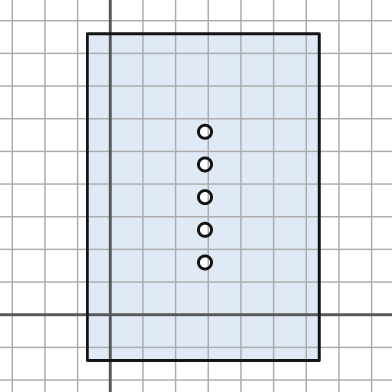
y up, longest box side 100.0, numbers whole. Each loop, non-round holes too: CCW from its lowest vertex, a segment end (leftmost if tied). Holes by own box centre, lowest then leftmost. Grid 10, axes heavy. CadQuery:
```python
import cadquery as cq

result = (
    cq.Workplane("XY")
    .moveTo(-7.0, -14.0)
    .lineTo(64.0, -14.0)
    .lineTo(64.0, 86.0)
    .lineTo(-7.0, 86.0)
    .close()
    .moveTo(29.0, 16.0)
    .circle(2.0)
    .moveTo(29.0, 26.0)
    .circle(2.0)
    .moveTo(29.0, 36.0)
    .circle(2.0)
    .moveTo(29.0, 46.0)
    .circle(2.0)
    .moveTo(29.0, 56.0)
    .circle(2.0)
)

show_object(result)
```